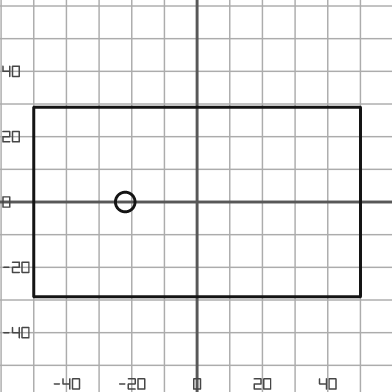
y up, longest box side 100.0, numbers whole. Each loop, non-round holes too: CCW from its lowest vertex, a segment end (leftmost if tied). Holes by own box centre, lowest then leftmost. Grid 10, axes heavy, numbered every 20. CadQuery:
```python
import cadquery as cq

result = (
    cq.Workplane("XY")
    .moveTo(-50.0, -29.0)
    .lineTo(50.0, -29.0)
    .lineTo(50.0, 29.0)
    .lineTo(-50.0, 29.0)
    .close()
    .moveTo(-22.0, 0.0)
    .circle(3.0)
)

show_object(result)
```